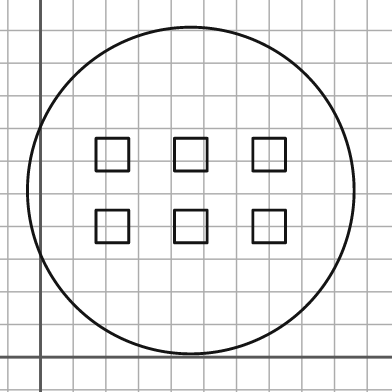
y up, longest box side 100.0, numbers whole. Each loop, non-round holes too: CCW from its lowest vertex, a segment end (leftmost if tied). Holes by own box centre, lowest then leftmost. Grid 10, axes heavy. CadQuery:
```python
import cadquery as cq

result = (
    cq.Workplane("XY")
    .moveTo(46.0, 51.0)
    .circle(50.0)
    .moveTo(17.0, 35.0)
    .lineTo(27.0, 35.0)
    .lineTo(27.0, 45.0)
    .lineTo(17.0, 45.0)
    .close()
    .moveTo(41.0, 35.0)
    .lineTo(51.0, 35.0)
    .lineTo(51.0, 45.0)
    .lineTo(41.0, 45.0)
    .close()
    .moveTo(65.0, 35.0)
    .lineTo(75.0, 35.0)
    .lineTo(75.0, 45.0)
    .lineTo(65.0, 45.0)
    .close()
    .moveTo(17.0, 57.0)
    .lineTo(27.0, 57.0)
    .lineTo(27.0, 67.0)
    .lineTo(17.0, 67.0)
    .close()
    .moveTo(41.0, 57.0)
    .lineTo(51.0, 57.0)
    .lineTo(51.0, 67.0)
    .lineTo(41.0, 67.0)
    .close()
    .moveTo(65.0, 57.0)
    .lineTo(75.0, 57.0)
    .lineTo(75.0, 67.0)
    .lineTo(65.0, 67.0)
    .close()
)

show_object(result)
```